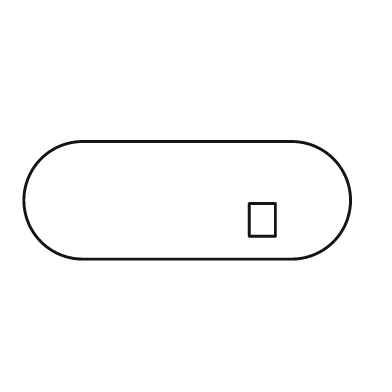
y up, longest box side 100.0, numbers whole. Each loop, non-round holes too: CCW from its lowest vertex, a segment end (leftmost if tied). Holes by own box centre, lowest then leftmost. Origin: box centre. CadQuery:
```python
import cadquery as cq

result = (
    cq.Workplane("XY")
    .moveTo(-32.0, -18.0)
    .lineTo(32.0, -18.0)
    .threePointArc((50.0, 0.0), (32.0, 18.0))
    .lineTo(-32.0, 18.0)
    .threePointArc((-50.0, 0.0), (-32.0, -18.0))
    .close()
    .moveTo(19.0, -11.0)
    .lineTo(27.0, -11.0)
    .lineTo(27.0, -1.0)
    .lineTo(19.0, -1.0)
    .close()
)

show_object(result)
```